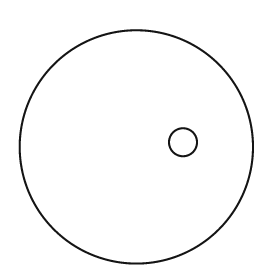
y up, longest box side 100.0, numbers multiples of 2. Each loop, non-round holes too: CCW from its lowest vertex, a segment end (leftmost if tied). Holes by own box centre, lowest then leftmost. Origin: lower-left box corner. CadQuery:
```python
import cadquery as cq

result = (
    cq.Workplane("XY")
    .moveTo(50.0, 50.0)
    .circle(50.0)
    .moveTo(70.0, 52.0)
    .circle(6.0)
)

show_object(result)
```